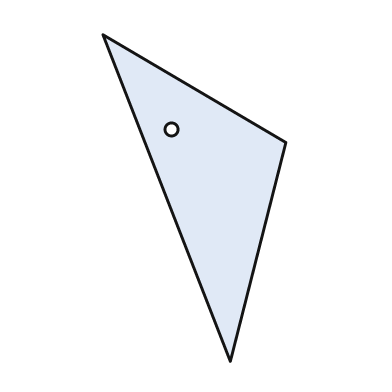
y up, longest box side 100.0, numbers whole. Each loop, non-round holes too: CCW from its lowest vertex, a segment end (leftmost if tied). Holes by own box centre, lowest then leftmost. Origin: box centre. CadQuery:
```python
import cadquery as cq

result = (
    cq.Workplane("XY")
    .moveTo(11.0, -50.0)
    .lineTo(28.0, 17.0)
    .lineTo(-28.0, 50.0)
    .close()
    .moveTo(-7.0, 21.0)
    .circle(2.0)
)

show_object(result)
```